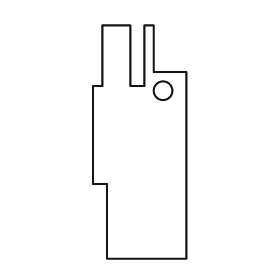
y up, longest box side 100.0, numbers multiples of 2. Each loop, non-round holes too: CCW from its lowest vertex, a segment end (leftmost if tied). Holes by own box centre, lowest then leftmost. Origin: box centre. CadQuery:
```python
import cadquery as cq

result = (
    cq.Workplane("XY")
    .moveTo(-14.0, -50.0)
    .lineTo(20.0, -50.0)
    .lineTo(20.0, 30.0)
    .lineTo(6.0, 30.0)
    .lineTo(6.0, 50.0)
    .lineTo(2.0, 50.0)
    .lineTo(2.0, 24.0)
    .lineTo(-4.0, 24.0)
    .lineTo(-4.0, 50.0)
    .lineTo(-16.0, 50.0)
    .lineTo(-16.0, 24.0)
    .lineTo(-20.0, 24.0)
    .lineTo(-20.0, -18.0)
    .lineTo(-14.0, -18.0)
    .close()
    .moveTo(10.0, 22.0)
    .circle(4.0)
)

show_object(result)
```